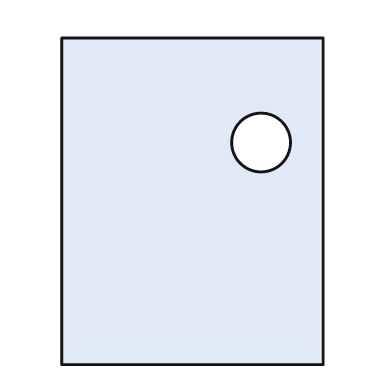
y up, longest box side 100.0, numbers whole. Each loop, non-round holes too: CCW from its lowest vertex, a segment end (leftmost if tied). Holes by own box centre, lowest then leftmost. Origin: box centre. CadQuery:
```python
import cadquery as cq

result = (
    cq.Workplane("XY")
    .moveTo(-40.0, -50.0)
    .lineTo(40.0, -50.0)
    .lineTo(40.0, 50.0)
    .lineTo(-40.0, 50.0)
    .close()
    .moveTo(21.0, 18.0)
    .circle(9.0)
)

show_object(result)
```